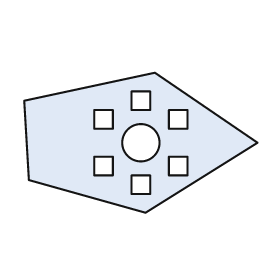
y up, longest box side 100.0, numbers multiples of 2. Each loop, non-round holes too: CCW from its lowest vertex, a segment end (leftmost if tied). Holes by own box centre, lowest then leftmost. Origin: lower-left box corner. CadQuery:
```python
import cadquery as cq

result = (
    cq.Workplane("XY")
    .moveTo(52.0, 0.0)
    .lineTo(100.0, 30.0)
    .lineTo(56.0, 60.0)
    .lineTo(0.0, 48.0)
    .lineTo(2.0, 14.0)
    .close()
    .moveTo(46.0, 8.0)
    .lineTo(54.0, 8.0)
    .lineTo(54.0, 16.0)
    .lineTo(46.0, 16.0)
    .close()
    .moveTo(30.0, 16.0)
    .lineTo(38.0, 16.0)
    .lineTo(38.0, 24.0)
    .lineTo(30.0, 24.0)
    .close()
    .moveTo(62.0, 16.0)
    .lineTo(70.0, 16.0)
    .lineTo(70.0, 24.0)
    .lineTo(62.0, 24.0)
    .close()
    .moveTo(50.0, 30.0)
    .circle(8.0)
    .moveTo(30.0, 36.0)
    .lineTo(38.0, 36.0)
    .lineTo(38.0, 44.0)
    .lineTo(30.0, 44.0)
    .close()
    .moveTo(62.0, 36.0)
    .lineTo(70.0, 36.0)
    .lineTo(70.0, 44.0)
    .lineTo(62.0, 44.0)
    .close()
    .moveTo(46.0, 44.0)
    .lineTo(54.0, 44.0)
    .lineTo(54.0, 52.0)
    .lineTo(46.0, 52.0)
    .close()
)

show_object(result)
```